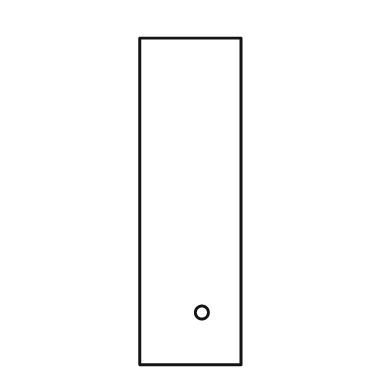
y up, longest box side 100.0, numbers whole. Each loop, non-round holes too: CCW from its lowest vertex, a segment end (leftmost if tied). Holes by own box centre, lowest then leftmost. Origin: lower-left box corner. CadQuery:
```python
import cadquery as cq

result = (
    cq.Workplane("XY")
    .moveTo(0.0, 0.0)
    .lineTo(31.0, 0.0)
    .lineTo(31.0, 100.0)
    .lineTo(0.0, 100.0)
    .close()
    .moveTo(19.0, 16.0)
    .circle(2.0)
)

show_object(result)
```